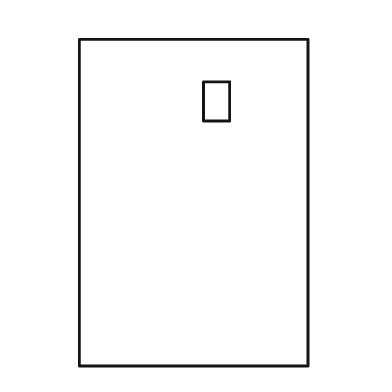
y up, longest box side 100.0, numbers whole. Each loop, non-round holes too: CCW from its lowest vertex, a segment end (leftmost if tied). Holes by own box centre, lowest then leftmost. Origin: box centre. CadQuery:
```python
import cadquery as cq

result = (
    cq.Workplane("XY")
    .moveTo(-35.0, -50.0)
    .lineTo(35.0, -50.0)
    .lineTo(35.0, 50.0)
    .lineTo(-35.0, 50.0)
    .close()
    .moveTo(3.0, 25.0)
    .lineTo(11.0, 25.0)
    .lineTo(11.0, 37.0)
    .lineTo(3.0, 37.0)
    .close()
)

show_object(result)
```